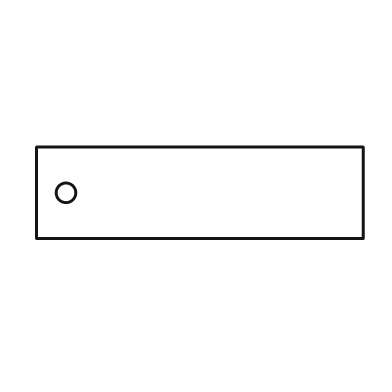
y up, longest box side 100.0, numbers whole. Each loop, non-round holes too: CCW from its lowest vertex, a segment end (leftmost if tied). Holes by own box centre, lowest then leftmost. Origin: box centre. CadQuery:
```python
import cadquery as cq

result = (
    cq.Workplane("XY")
    .moveTo(-50.0, -14.0)
    .lineTo(50.0, -14.0)
    .lineTo(50.0, 14.0)
    .lineTo(-50.0, 14.0)
    .close()
    .moveTo(-41.0, 0.0)
    .circle(3.0)
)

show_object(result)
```